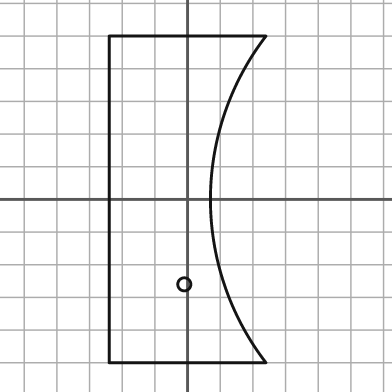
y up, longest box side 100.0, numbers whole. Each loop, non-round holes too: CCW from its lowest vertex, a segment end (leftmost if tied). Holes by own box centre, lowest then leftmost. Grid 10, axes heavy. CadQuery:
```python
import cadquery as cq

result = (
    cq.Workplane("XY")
    .moveTo(-24.0, -50.0)
    .lineTo(24.0, -50.0)
    .threePointArc((7.0, 0.0), (24.0, 50.0))
    .lineTo(-24.0, 50.0)
    .close()
    .moveTo(-1.0, -26.0)
    .circle(2.0)
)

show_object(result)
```